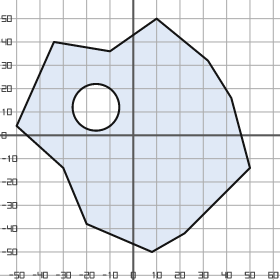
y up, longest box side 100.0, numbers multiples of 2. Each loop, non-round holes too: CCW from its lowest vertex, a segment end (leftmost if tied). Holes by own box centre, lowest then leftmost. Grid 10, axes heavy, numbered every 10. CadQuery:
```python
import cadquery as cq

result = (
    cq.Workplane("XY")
    .moveTo(8.0, -50.0)
    .lineTo(22.0, -42.0)
    .lineTo(50.0, -14.0)
    .lineTo(42.0, 16.0)
    .lineTo(32.0, 32.0)
    .lineTo(10.0, 50.0)
    .lineTo(-10.0, 36.0)
    .lineTo(-34.0, 40.0)
    .lineTo(-50.0, 4.0)
    .lineTo(-30.0, -14.0)
    .lineTo(-20.0, -38.0)
    .close()
    .moveTo(-16.0, 12.0)
    .circle(10.0)
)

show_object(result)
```